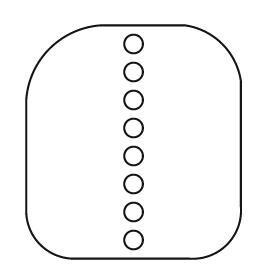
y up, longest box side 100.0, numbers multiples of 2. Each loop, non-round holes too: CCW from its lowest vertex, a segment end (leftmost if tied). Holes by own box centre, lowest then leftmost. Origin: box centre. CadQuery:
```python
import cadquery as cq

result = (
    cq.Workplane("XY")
    .moveTo(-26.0, -50.0)
    .lineTo(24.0, -50.0)
    .threePointArc((40.0, -44.0), (46.0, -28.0))
    .lineTo(46.0, 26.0)
    .threePointArc((38.0, 42.0), (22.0, 50.0))
    .lineTo(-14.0, 50.0)
    .threePointArc((-36.0, 40.0), (-46.0, 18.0))
    .lineTo(-46.0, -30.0)
    .threePointArc((-40.0, -44.0), (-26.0, -50.0))
    .close()
    .moveTo(0.0, -42.0)
    .circle(4.0)
    .moveTo(0.0, -30.0)
    .circle(4.0)
    .moveTo(0.0, -18.0)
    .circle(4.0)
    .moveTo(0.0, -6.0)
    .circle(4.0)
    .moveTo(0.0, 6.0)
    .circle(4.0)
    .moveTo(0.0, 18.0)
    .circle(4.0)
    .moveTo(0.0, 30.0)
    .circle(4.0)
    .moveTo(0.0, 42.0)
    .circle(4.0)
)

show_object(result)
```